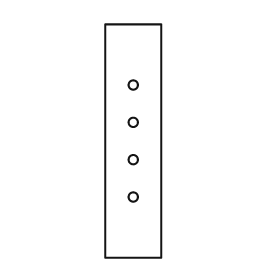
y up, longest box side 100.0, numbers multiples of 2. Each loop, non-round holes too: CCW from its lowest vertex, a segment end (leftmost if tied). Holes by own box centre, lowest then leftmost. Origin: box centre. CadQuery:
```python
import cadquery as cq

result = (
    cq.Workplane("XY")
    .moveTo(-12.0, -50.0)
    .lineTo(12.0, -50.0)
    .lineTo(12.0, 50.0)
    .lineTo(-12.0, 50.0)
    .close()
    .moveTo(0.0, -24.0)
    .circle(2.0)
    .moveTo(0.0, -8.0)
    .circle(2.0)
    .moveTo(0.0, 8.0)
    .circle(2.0)
    .moveTo(0.0, 24.0)
    .circle(2.0)
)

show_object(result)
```